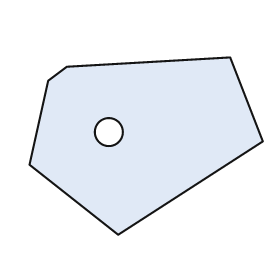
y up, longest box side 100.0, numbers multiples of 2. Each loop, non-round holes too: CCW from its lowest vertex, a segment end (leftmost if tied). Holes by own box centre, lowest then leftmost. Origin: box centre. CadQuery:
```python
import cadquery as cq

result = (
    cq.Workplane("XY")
    .moveTo(-12.0, -38.0)
    .lineTo(50.0, 2.0)
    .lineTo(36.0, 38.0)
    .lineTo(-34.0, 34.0)
    .lineTo(-42.0, 28.0)
    .lineTo(-50.0, -8.0)
    .close()
    .moveTo(-16.0, 6.0)
    .circle(6.0)
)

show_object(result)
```